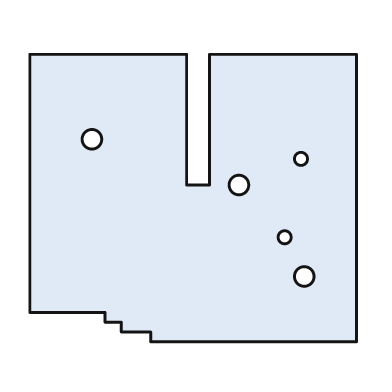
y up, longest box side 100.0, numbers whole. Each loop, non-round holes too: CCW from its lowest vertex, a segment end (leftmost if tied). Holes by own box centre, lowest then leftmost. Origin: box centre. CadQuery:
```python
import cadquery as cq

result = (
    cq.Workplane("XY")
    .moveTo(-13.0, -44.0)
    .lineTo(50.0, -44.0)
    .lineTo(50.0, 44.0)
    .lineTo(5.0, 44.0)
    .lineTo(5.0, 4.0)
    .lineTo(-2.0, 4.0)
    .lineTo(-2.0, 44.0)
    .lineTo(-50.0, 44.0)
    .lineTo(-50.0, -35.0)
    .lineTo(-27.0, -35.0)
    .lineTo(-27.0, -38.0)
    .lineTo(-22.0, -38.0)
    .lineTo(-22.0, -41.0)
    .lineTo(-13.0, -41.0)
    .close()
    .moveTo(34.0, -24.0)
    .circle(3.0)
    .moveTo(28.0, -12.0)
    .circle(2.0)
    .moveTo(14.0, 4.0)
    .circle(3.0)
    .moveTo(33.0, 12.0)
    .circle(2.0)
    .moveTo(-31.0, 18.0)
    .circle(3.0)
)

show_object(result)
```